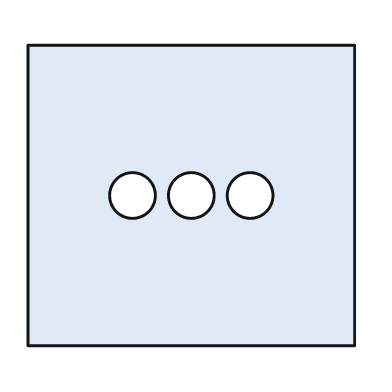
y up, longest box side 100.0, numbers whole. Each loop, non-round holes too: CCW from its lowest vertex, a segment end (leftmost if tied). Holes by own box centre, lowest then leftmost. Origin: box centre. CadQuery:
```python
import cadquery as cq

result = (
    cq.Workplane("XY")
    .moveTo(-50.0, -46.0)
    .lineTo(50.0, -46.0)
    .lineTo(50.0, 46.0)
    .lineTo(-50.0, 46.0)
    .close()
    .moveTo(-18.0, 0.0)
    .circle(7.0)
    .moveTo(0.0, 0.0)
    .circle(7.0)
    .moveTo(18.0, 0.0)
    .circle(7.0)
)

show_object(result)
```